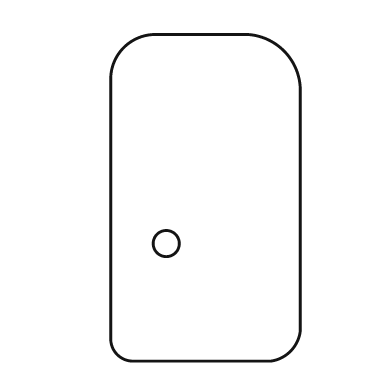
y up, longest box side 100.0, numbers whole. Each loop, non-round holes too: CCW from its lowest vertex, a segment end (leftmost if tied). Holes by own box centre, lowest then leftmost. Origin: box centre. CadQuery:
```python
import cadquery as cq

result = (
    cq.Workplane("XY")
    .moveTo(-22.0, -50.0)
    .lineTo(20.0, -50.0)
    .threePointArc((26.0, -47.0), (29.0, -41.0))
    .lineTo(29.0, 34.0)
    .threePointArc((24.0, 45.0), (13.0, 50.0))
    .lineTo(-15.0, 50.0)
    .threePointArc((-25.0, 46.0), (-29.0, 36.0))
    .lineTo(-29.0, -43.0)
    .threePointArc((-27.0, -48.0), (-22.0, -50.0))
    .close()
    .moveTo(-12.0, -14.0)
    .circle(4.0)
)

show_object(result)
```